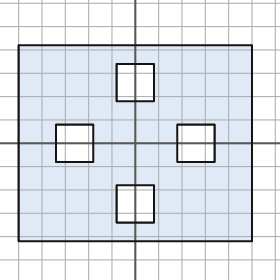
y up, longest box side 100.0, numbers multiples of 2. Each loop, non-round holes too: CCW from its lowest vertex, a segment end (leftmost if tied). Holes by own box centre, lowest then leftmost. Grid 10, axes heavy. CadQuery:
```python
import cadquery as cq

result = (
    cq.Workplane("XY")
    .moveTo(-50.0, -42.0)
    .lineTo(50.0, -42.0)
    .lineTo(50.0, 42.0)
    .lineTo(-50.0, 42.0)
    .close()
    .moveTo(-8.0, -34.0)
    .lineTo(8.0, -34.0)
    .lineTo(8.0, -18.0)
    .lineTo(-8.0, -18.0)
    .close()
    .moveTo(-34.0, -8.0)
    .lineTo(-18.0, -8.0)
    .lineTo(-18.0, 8.0)
    .lineTo(-34.0, 8.0)
    .close()
    .moveTo(18.0, -8.0)
    .lineTo(34.0, -8.0)
    .lineTo(34.0, 8.0)
    .lineTo(18.0, 8.0)
    .close()
    .moveTo(-8.0, 18.0)
    .lineTo(8.0, 18.0)
    .lineTo(8.0, 34.0)
    .lineTo(-8.0, 34.0)
    .close()
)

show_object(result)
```